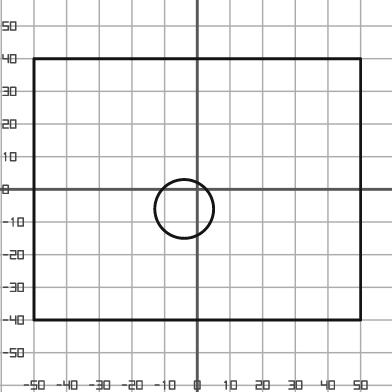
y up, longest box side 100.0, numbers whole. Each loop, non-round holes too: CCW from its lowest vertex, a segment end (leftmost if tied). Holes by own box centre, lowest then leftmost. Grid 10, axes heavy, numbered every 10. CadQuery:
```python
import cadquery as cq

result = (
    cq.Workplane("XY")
    .moveTo(-50.0, -40.0)
    .lineTo(50.0, -40.0)
    .lineTo(50.0, 40.0)
    .lineTo(-50.0, 40.0)
    .close()
    .moveTo(-4.0, -6.0)
    .circle(9.0)
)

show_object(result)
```